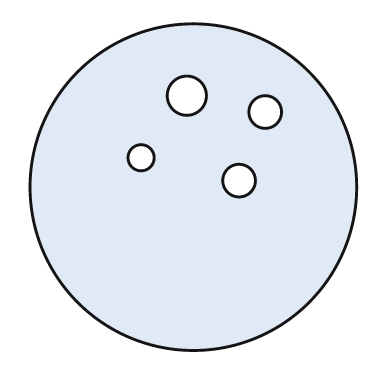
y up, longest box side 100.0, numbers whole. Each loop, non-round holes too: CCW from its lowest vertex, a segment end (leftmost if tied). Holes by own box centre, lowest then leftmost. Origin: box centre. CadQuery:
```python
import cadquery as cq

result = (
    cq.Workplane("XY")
    .moveTo(0.0, 0.0)
    .circle(50.0)
    .moveTo(14.0, 2.0)
    .circle(5.0)
    .moveTo(-16.0, 9.0)
    .circle(4.0)
    .moveTo(22.0, 23.0)
    .circle(5.0)
    .moveTo(-2.0, 28.0)
    .circle(6.0)
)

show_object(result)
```